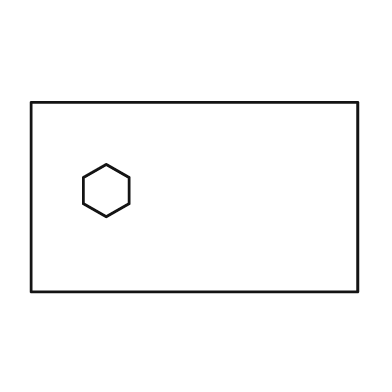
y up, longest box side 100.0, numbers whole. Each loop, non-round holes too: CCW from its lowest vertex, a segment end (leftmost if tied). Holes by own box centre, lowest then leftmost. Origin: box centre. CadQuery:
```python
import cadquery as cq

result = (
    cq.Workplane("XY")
    .moveTo(-50.0, -29.0)
    .lineTo(50.0, -29.0)
    .lineTo(50.0, 29.0)
    .lineTo(-50.0, 29.0)
    .close()
    .moveTo(-27.0, -6.0)
    .lineTo(-20.0, -2.0)
    .lineTo(-20.0, 6.0)
    .lineTo(-27.0, 10.0)
    .lineTo(-34.0, 6.0)
    .lineTo(-34.0, -2.0)
    .close()
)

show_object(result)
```